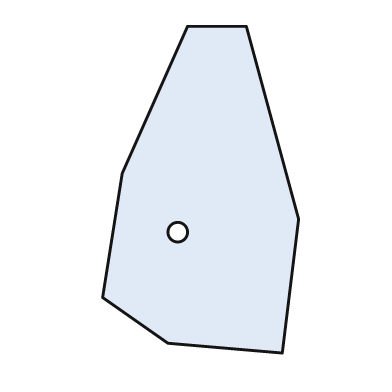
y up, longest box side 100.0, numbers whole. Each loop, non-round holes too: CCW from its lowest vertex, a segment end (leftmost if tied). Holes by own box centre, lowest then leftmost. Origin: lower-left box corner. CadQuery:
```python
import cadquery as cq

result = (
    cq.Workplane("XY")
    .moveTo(55.0, 0.0)
    .lineTo(60.0, 41.0)
    .lineTo(44.0, 100.0)
    .lineTo(26.0, 100.0)
    .lineTo(6.0, 55.0)
    .lineTo(0.0, 17.0)
    .lineTo(20.0, 3.0)
    .close()
    .moveTo(23.0, 37.0)
    .circle(3.0)
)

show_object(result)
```